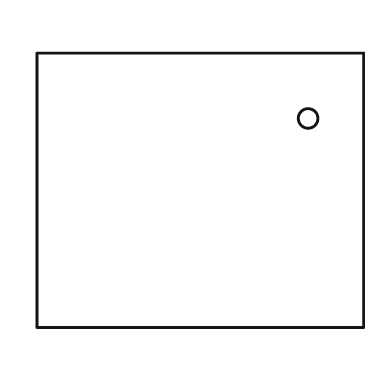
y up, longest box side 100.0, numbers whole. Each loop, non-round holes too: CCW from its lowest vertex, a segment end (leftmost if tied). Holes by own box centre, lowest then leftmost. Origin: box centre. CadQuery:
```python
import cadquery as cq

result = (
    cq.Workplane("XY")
    .moveTo(-50.0, -42.0)
    .lineTo(50.0, -42.0)
    .lineTo(50.0, 42.0)
    .lineTo(-50.0, 42.0)
    .close()
    .moveTo(33.0, 22.0)
    .circle(3.0)
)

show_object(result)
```